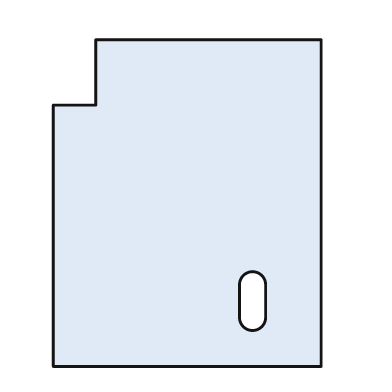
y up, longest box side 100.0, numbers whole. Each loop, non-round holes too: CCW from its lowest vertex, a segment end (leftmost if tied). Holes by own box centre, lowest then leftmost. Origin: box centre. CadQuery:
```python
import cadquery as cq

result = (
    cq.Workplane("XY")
    .moveTo(-41.0, -50.0)
    .lineTo(41.0, -50.0)
    .lineTo(41.0, 50.0)
    .lineTo(-28.0, 50.0)
    .lineTo(-28.0, 30.0)
    .lineTo(-41.0, 30.0)
    .close()
    .moveTo(16.0, -35.0)
    .threePointArc((20.0, -39.0), (24.0, -35.0))
    .lineTo(24.0, -25.0)
    .threePointArc((20.0, -21.0), (16.0, -25.0))
    .close()
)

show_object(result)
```